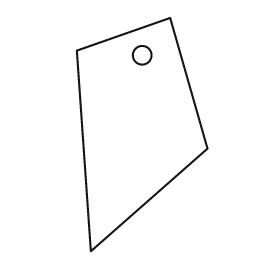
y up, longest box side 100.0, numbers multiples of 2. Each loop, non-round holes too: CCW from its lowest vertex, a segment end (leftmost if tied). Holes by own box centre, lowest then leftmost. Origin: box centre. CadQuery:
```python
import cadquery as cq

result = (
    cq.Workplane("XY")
    .moveTo(-22.0, -50.0)
    .lineTo(28.0, -6.0)
    .lineTo(12.0, 50.0)
    .lineTo(-28.0, 36.0)
    .close()
    .moveTo(0.0, 34.0)
    .circle(4.0)
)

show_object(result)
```